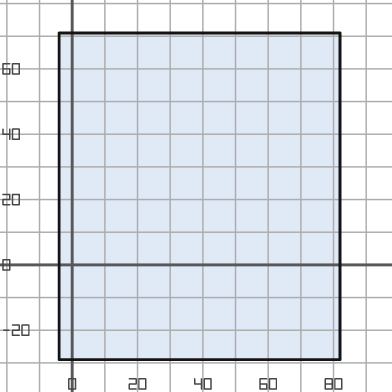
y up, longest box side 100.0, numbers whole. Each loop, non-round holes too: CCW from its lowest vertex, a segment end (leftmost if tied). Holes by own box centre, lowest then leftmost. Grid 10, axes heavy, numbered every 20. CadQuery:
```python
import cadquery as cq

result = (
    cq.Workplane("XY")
    .moveTo(-4.0, -29.0)
    .lineTo(82.0, -29.0)
    .lineTo(82.0, 71.0)
    .lineTo(-4.0, 71.0)
    .close()
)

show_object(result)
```